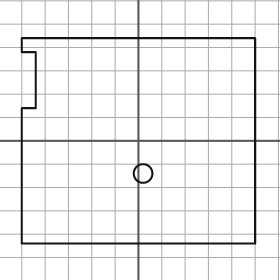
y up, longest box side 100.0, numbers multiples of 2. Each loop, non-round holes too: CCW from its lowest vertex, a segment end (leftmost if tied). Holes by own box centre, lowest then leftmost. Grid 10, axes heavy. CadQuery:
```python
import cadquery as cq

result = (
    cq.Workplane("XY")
    .moveTo(-50.0, -44.0)
    .lineTo(50.0, -44.0)
    .lineTo(50.0, 44.0)
    .lineTo(-50.0, 44.0)
    .lineTo(-50.0, 38.0)
    .lineTo(-44.0, 38.0)
    .lineTo(-44.0, 14.0)
    .lineTo(-50.0, 14.0)
    .close()
    .moveTo(2.0, -14.0)
    .circle(4.0)
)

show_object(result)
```